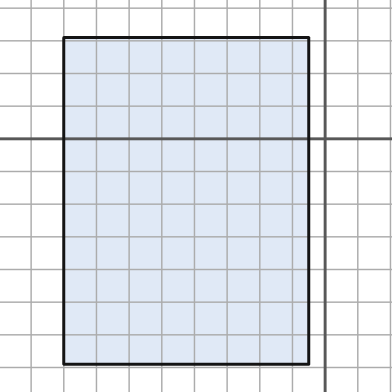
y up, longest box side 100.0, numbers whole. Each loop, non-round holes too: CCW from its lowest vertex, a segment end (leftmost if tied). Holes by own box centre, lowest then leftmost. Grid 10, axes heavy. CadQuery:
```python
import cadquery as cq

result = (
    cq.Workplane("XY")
    .moveTo(-80.0, -69.0)
    .lineTo(-5.0, -69.0)
    .lineTo(-5.0, 31.0)
    .lineTo(-80.0, 31.0)
    .close()
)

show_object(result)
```